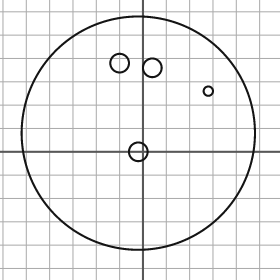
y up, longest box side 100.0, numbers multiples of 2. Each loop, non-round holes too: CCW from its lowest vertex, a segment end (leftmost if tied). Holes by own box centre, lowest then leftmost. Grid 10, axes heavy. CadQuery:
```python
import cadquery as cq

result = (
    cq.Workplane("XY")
    .moveTo(-2.0, 8.0)
    .circle(50.0)
    .moveTo(-2.0, 0.0)
    .circle(4.0)
    .moveTo(28.0, 26.0)
    .circle(2.0)
    .moveTo(4.0, 36.0)
    .circle(4.0)
    .moveTo(-10.0, 38.0)
    .circle(4.0)
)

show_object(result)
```